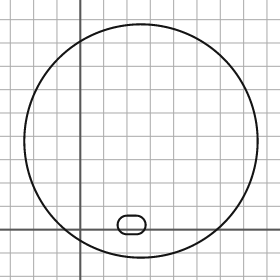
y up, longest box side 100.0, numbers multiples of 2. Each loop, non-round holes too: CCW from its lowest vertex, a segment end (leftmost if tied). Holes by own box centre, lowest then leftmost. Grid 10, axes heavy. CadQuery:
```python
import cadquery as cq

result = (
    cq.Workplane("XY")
    .moveTo(26.0, 38.0)
    .circle(50.0)
    .moveTo(20.0, -2.0)
    .lineTo(24.0, -2.0)
    .threePointArc((28.0, 2.0), (24.0, 6.0))
    .lineTo(20.0, 6.0)
    .threePointArc((16.0, 2.0), (20.0, -2.0))
    .close()
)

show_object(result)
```